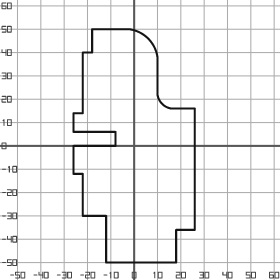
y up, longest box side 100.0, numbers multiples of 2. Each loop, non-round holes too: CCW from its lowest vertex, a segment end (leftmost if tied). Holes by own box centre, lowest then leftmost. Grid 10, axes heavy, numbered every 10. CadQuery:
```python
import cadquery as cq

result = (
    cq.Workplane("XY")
    .moveTo(-12.0, -50.0)
    .lineTo(18.0, -50.0)
    .lineTo(18.0, -36.0)
    .lineTo(26.0, -36.0)
    .lineTo(26.0, 16.0)
    .lineTo(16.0, 16.0)
    .threePointArc((12.0, 18.0), (10.0, 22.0))
    .lineTo(10.0, 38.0)
    .threePointArc((6.0, 46.0), (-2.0, 50.0))
    .lineTo(-18.0, 50.0)
    .lineTo(-18.0, 40.0)
    .lineTo(-22.0, 40.0)
    .lineTo(-22.0, 14.0)
    .lineTo(-26.0, 14.0)
    .lineTo(-26.0, 6.0)
    .lineTo(-8.0, 6.0)
    .lineTo(-8.0, 0.0)
    .lineTo(-26.0, 0.0)
    .lineTo(-26.0, -12.0)
    .lineTo(-22.0, -12.0)
    .lineTo(-22.0, -30.0)
    .lineTo(-12.0, -30.0)
    .close()
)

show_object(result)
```